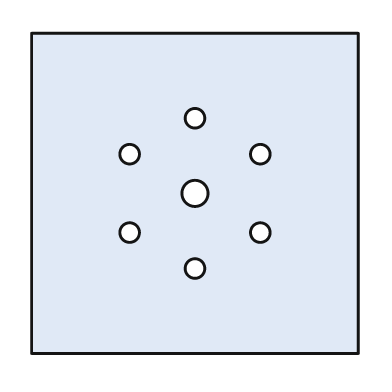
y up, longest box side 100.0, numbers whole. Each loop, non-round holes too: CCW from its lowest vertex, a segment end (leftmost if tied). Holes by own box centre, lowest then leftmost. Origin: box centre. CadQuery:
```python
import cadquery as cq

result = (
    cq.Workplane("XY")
    .moveTo(-50.0, -49.0)
    .lineTo(50.0, -49.0)
    .lineTo(50.0, 49.0)
    .lineTo(-50.0, 49.0)
    .close()
    .moveTo(0.0, -23.0)
    .circle(3.0)
    .moveTo(-20.0, -12.0)
    .circle(3.0)
    .moveTo(20.0, -12.0)
    .circle(3.0)
    .moveTo(0.0, 0.0)
    .circle(4.0)
    .moveTo(-20.0, 12.0)
    .circle(3.0)
    .moveTo(20.0, 12.0)
    .circle(3.0)
    .moveTo(0.0, 23.0)
    .circle(3.0)
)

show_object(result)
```